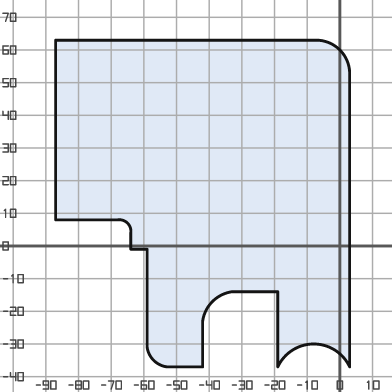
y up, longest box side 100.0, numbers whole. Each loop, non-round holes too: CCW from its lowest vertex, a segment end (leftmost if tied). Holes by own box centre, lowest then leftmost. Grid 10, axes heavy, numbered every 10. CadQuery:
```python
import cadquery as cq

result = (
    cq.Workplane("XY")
    .moveTo(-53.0, -37.0)
    .lineTo(-42.0, -37.0)
    .lineTo(-42.0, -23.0)
    .threePointArc((-39.0, -17.0), (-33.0, -14.0))
    .lineTo(-19.0, -14.0)
    .lineTo(-19.0, -37.0)
    .threePointArc((-8.0, -30.0), (3.0, -37.0))
    .lineTo(3.0, 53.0)
    .threePointArc((0.0, 60.0), (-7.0, 63.0))
    .lineTo(-87.0, 63.0)
    .lineTo(-87.0, 8.0)
    .lineTo(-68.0, 8.0)
    .threePointArc((-65.0, 7.0), (-64.0, 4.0))
    .lineTo(-64.0, -1.0)
    .lineTo(-59.0, -1.0)
    .lineTo(-59.0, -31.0)
    .threePointArc((-57.0, -35.0), (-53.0, -37.0))
    .close()
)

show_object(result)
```